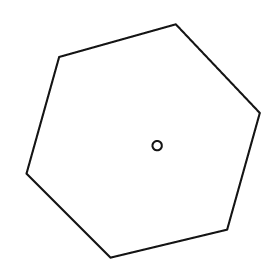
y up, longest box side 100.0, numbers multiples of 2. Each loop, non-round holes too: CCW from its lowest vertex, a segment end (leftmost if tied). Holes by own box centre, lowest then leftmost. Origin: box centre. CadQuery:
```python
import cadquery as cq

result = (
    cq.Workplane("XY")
    .moveTo(-14.0, -50.0)
    .lineTo(36.0, -38.0)
    .lineTo(50.0, 12.0)
    .lineTo(14.0, 50.0)
    .lineTo(-36.0, 36.0)
    .lineTo(-50.0, -14.0)
    .close()
    .moveTo(6.0, -2.0)
    .circle(2.0)
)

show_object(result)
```